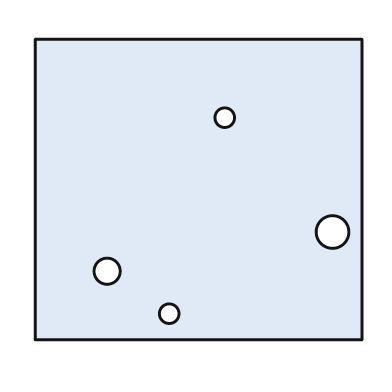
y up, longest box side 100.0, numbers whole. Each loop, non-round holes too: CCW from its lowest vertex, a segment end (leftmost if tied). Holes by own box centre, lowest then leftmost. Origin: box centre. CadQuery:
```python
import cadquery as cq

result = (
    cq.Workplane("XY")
    .moveTo(-50.0, -46.0)
    .lineTo(50.0, -46.0)
    .lineTo(50.0, 46.0)
    .lineTo(-50.0, 46.0)
    .close()
    .moveTo(-9.0, -38.0)
    .circle(3.0)
    .moveTo(-28.0, -25.0)
    .circle(4.0)
    .moveTo(41.0, -13.0)
    .circle(5.0)
    .moveTo(8.0, 22.0)
    .circle(3.0)
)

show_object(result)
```